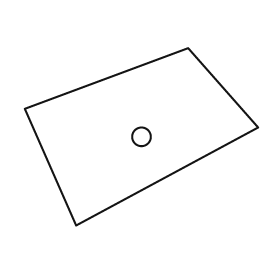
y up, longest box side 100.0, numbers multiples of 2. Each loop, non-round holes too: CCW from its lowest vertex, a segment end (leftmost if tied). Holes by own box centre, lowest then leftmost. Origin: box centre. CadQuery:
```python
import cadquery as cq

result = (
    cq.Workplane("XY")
    .moveTo(-28.0, -38.0)
    .lineTo(50.0, 4.0)
    .lineTo(20.0, 38.0)
    .lineTo(-50.0, 12.0)
    .close()
    .moveTo(0.0, 0.0)
    .circle(4.0)
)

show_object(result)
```